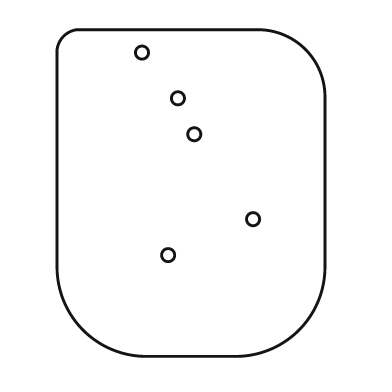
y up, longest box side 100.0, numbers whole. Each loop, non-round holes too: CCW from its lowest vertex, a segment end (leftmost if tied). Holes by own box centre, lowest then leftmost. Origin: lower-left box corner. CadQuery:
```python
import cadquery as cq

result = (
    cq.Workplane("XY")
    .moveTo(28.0, 0.0)
    .lineTo(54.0, 0.0)
    .threePointArc((74.0, 8.0), (82.0, 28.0))
    .lineTo(82.0, 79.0)
    .threePointArc((76.0, 94.0), (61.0, 100.0))
    .lineTo(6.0, 100.0)
    .threePointArc((2.0, 98.0), (0.0, 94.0))
    .lineTo(0.0, 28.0)
    .threePointArc((8.0, 8.0), (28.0, 0.0))
    .close()
    .moveTo(34.0, 31.0)
    .circle(2.0)
    .moveTo(60.0, 42.0)
    .circle(2.0)
    .moveTo(42.0, 68.0)
    .circle(2.0)
    .moveTo(37.0, 79.0)
    .circle(2.0)
    .moveTo(26.0, 93.0)
    .circle(2.0)
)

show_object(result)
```